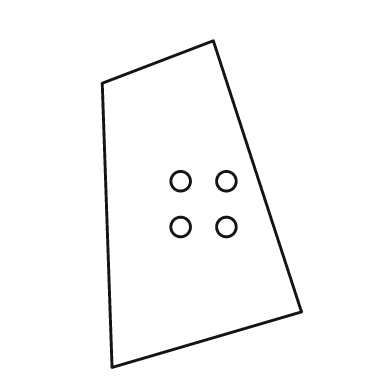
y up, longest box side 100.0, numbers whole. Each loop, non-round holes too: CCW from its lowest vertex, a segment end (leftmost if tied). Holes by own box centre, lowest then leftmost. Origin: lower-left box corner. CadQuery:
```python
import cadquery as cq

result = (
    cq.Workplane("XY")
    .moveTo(3.0, 0.0)
    .lineTo(61.0, 17.0)
    .lineTo(34.0, 100.0)
    .lineTo(0.0, 87.0)
    .close()
    .moveTo(24.0, 43.0)
    .circle(3.0)
    .moveTo(38.0, 43.0)
    .circle(3.0)
    .moveTo(24.0, 57.0)
    .circle(3.0)
    .moveTo(38.0, 57.0)
    .circle(3.0)
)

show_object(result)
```